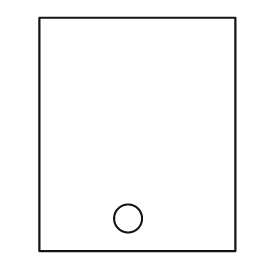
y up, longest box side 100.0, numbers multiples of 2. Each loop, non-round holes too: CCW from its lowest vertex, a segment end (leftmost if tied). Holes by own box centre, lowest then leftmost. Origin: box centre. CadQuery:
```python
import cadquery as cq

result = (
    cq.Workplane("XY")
    .moveTo(-42.0, -50.0)
    .lineTo(42.0, -50.0)
    .lineTo(42.0, 50.0)
    .lineTo(-42.0, 50.0)
    .close()
    .moveTo(-4.0, -36.0)
    .circle(6.0)
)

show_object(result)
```